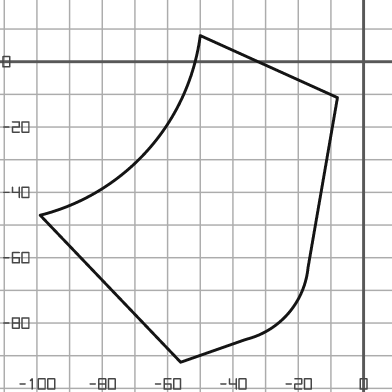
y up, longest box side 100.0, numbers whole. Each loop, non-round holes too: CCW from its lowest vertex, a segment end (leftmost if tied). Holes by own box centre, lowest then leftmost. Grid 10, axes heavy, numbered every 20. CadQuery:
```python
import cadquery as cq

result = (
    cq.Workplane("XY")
    .moveTo(-56.0, -92.0)
    .lineTo(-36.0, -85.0)
    .threePointArc((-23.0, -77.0), (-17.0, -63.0))
    .lineTo(-8.0, -11.0)
    .lineTo(-50.0, 8.0)
    .threePointArc((-66.0, -27.0), (-99.0, -47.0))
    .close()
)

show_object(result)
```